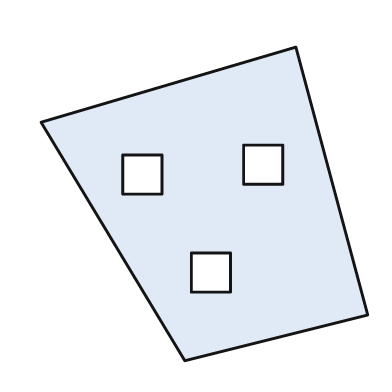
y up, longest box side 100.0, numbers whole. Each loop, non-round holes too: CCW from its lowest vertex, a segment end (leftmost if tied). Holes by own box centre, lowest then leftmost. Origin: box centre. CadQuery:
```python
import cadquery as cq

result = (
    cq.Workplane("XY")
    .moveTo(-6.0, -48.0)
    .lineTo(50.0, -34.0)
    .lineTo(28.0, 48.0)
    .lineTo(-50.0, 25.0)
    .close()
    .moveTo(-4.0, -27.0)
    .lineTo(8.0, -27.0)
    .lineTo(8.0, -15.0)
    .lineTo(-4.0, -15.0)
    .close()
    .moveTo(-25.0, 3.0)
    .lineTo(-13.0, 3.0)
    .lineTo(-13.0, 15.0)
    .lineTo(-25.0, 15.0)
    .close()
    .moveTo(12.0, 6.0)
    .lineTo(24.0, 6.0)
    .lineTo(24.0, 18.0)
    .lineTo(12.0, 18.0)
    .close()
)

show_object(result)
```